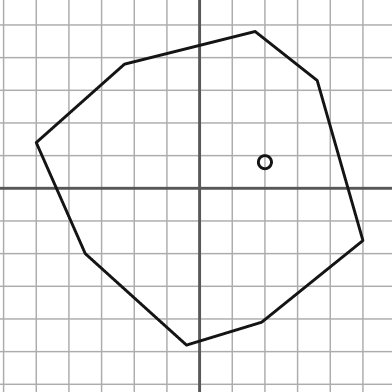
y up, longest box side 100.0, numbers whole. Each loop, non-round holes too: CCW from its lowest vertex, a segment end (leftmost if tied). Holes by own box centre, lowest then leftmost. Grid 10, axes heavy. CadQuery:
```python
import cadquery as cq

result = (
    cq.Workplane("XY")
    .moveTo(-4.0, -48.0)
    .lineTo(19.0, -41.0)
    .lineTo(50.0, -16.0)
    .lineTo(36.0, 33.0)
    .lineTo(17.0, 48.0)
    .lineTo(-23.0, 38.0)
    .lineTo(-50.0, 14.0)
    .lineTo(-35.0, -20.0)
    .close()
    .moveTo(20.0, 8.0)
    .circle(2.0)
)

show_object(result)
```